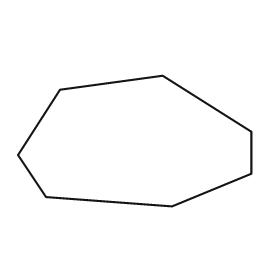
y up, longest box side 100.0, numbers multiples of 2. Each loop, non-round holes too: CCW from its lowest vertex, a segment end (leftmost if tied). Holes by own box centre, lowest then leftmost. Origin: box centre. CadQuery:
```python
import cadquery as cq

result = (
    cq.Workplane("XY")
    .moveTo(16.0, -28.0)
    .lineTo(50.0, -14.0)
    .lineTo(50.0, 4.0)
    .lineTo(12.0, 28.0)
    .lineTo(-32.0, 22.0)
    .lineTo(-50.0, -6.0)
    .lineTo(-38.0, -24.0)
    .close()
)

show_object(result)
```